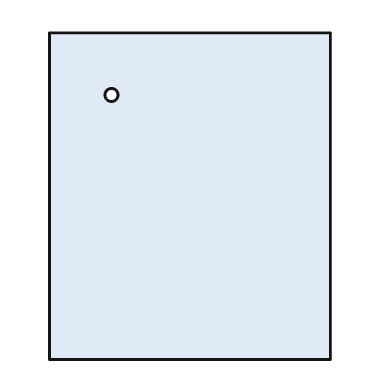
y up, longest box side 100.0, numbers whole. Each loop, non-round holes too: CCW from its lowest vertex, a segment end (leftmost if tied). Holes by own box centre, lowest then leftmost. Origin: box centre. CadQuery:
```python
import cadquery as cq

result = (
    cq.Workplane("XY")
    .moveTo(-43.0, -50.0)
    .lineTo(43.0, -50.0)
    .lineTo(43.0, 50.0)
    .lineTo(-43.0, 50.0)
    .close()
    .moveTo(-24.0, 31.0)
    .circle(2.0)
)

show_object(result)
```